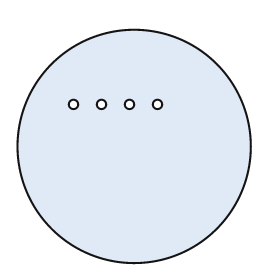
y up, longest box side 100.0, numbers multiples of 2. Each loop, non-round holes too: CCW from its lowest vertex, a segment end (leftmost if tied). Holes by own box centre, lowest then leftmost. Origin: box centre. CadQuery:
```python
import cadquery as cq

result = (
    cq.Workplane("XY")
    .moveTo(0.0, 0.0)
    .circle(50.0)
    .moveTo(-26.0, 18.0)
    .circle(2.0)
    .moveTo(-14.0, 18.0)
    .circle(2.0)
    .moveTo(-2.0, 18.0)
    .circle(2.0)
    .moveTo(10.0, 18.0)
    .circle(2.0)
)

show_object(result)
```